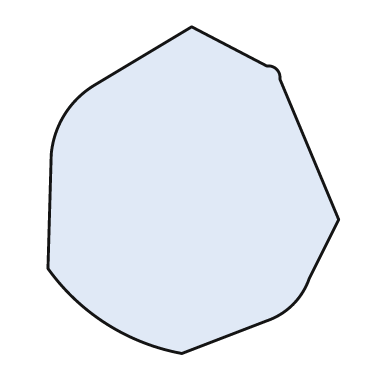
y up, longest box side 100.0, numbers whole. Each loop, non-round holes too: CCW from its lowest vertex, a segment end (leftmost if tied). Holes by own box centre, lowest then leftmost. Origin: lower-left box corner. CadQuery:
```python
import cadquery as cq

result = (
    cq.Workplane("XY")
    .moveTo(41.0, 0.0)
    .lineTo(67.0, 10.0)
    .threePointArc((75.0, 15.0), (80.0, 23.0))
    .lineTo(89.0, 41.0)
    .lineTo(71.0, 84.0)
    .threePointArc((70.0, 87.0), (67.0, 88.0))
    .lineTo(44.0, 100.0)
    .lineTo(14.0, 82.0)
    .threePointArc((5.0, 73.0), (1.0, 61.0))
    .lineTo(0.0, 26.0)
    .threePointArc((18.0, 9.0), (41.0, 0.0))
    .close()
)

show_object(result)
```